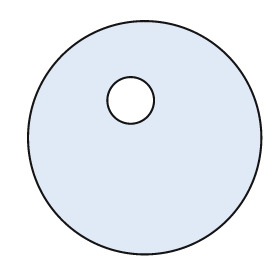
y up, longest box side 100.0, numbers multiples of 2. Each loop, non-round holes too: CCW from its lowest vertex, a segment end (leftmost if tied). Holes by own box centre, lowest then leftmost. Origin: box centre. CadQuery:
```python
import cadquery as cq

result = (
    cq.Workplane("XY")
    .moveTo(0.0, 0.0)
    .circle(50.0)
    .moveTo(-6.0, 16.0)
    .circle(10.0)
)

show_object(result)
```